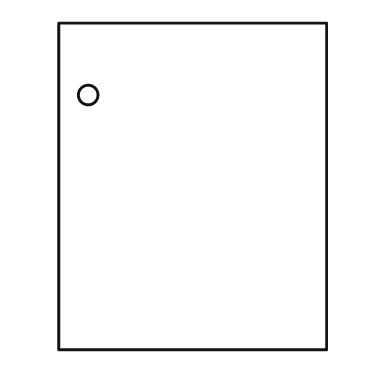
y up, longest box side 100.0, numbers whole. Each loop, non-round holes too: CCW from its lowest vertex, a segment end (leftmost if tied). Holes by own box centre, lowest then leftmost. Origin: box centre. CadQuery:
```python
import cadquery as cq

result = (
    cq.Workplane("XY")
    .moveTo(-41.0, -50.0)
    .lineTo(41.0, -50.0)
    .lineTo(41.0, 50.0)
    .lineTo(-41.0, 50.0)
    .close()
    .moveTo(-32.0, 28.0)
    .circle(3.0)
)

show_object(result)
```